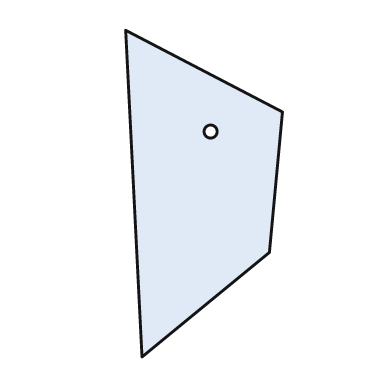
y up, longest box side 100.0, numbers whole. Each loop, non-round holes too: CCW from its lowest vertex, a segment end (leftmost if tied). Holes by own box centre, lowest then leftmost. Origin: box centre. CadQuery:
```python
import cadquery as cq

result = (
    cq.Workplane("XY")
    .moveTo(-19.0, -50.0)
    .lineTo(20.0, -18.0)
    .lineTo(24.0, 25.0)
    .lineTo(-24.0, 50.0)
    .close()
    .moveTo(2.0, 19.0)
    .circle(2.0)
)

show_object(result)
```